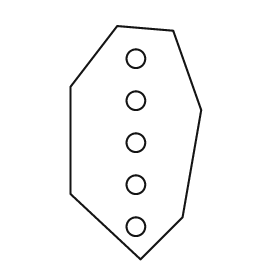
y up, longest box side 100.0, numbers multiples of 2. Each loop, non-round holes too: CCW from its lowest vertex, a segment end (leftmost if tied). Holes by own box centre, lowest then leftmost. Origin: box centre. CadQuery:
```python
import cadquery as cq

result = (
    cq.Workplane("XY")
    .moveTo(2.0, -50.0)
    .lineTo(20.0, -32.0)
    .lineTo(28.0, 14.0)
    .lineTo(16.0, 48.0)
    .lineTo(-8.0, 50.0)
    .lineTo(-28.0, 24.0)
    .lineTo(-28.0, -22.0)
    .close()
    .moveTo(0.0, -36.0)
    .circle(4.0)
    .moveTo(0.0, -18.0)
    .circle(4.0)
    .moveTo(0.0, 0.0)
    .circle(4.0)
    .moveTo(0.0, 18.0)
    .circle(4.0)
    .moveTo(0.0, 36.0)
    .circle(4.0)
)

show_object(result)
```